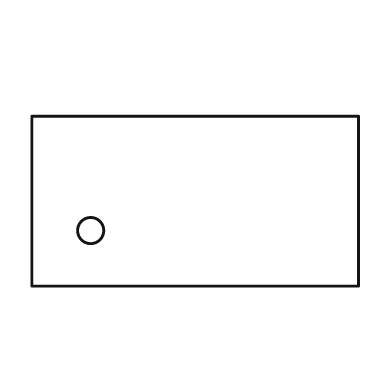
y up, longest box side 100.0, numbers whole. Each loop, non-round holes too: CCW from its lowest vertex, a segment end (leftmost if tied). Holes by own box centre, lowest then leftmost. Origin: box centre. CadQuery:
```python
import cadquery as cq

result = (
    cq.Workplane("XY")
    .moveTo(-50.0, -26.0)
    .lineTo(50.0, -26.0)
    .lineTo(50.0, 26.0)
    .lineTo(-50.0, 26.0)
    .close()
    .moveTo(-32.0, -9.0)
    .circle(4.0)
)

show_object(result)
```